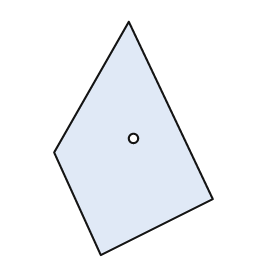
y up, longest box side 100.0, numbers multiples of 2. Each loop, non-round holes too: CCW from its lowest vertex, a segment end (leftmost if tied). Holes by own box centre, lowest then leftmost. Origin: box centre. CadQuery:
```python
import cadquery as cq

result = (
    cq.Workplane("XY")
    .moveTo(-14.0, -50.0)
    .lineTo(34.0, -26.0)
    .lineTo(-2.0, 50.0)
    .lineTo(-34.0, -6.0)
    .close()
    .moveTo(0.0, 0.0)
    .circle(2.0)
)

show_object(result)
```